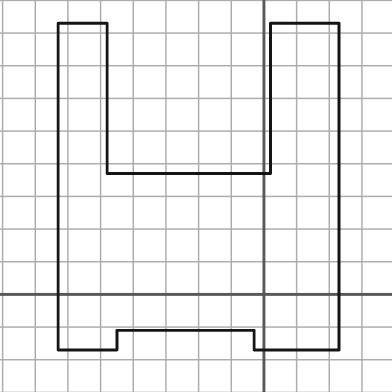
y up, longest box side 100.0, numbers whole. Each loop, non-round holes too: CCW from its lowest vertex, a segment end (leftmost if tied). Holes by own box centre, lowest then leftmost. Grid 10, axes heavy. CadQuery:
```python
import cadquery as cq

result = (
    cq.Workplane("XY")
    .moveTo(-63.0, -17.0)
    .lineTo(-45.0, -17.0)
    .lineTo(-45.0, -11.0)
    .lineTo(-3.0, -11.0)
    .lineTo(-3.0, -17.0)
    .lineTo(23.0, -17.0)
    .lineTo(23.0, 83.0)
    .lineTo(2.0, 83.0)
    .lineTo(2.0, 37.0)
    .lineTo(-48.0, 37.0)
    .lineTo(-48.0, 83.0)
    .lineTo(-63.0, 83.0)
    .close()
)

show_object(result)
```